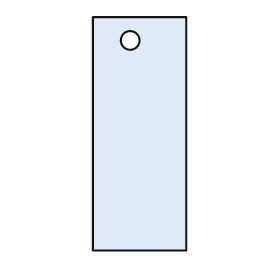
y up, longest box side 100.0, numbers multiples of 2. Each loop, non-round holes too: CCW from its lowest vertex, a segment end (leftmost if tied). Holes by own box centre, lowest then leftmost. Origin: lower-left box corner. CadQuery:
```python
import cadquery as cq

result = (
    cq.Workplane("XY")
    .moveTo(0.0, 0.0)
    .lineTo(40.0, 0.0)
    .lineTo(40.0, 100.0)
    .lineTo(0.0, 100.0)
    .close()
    .moveTo(16.0, 90.0)
    .circle(4.0)
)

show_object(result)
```